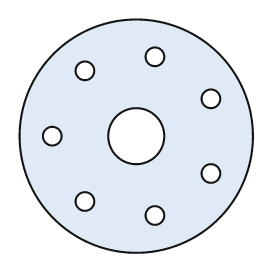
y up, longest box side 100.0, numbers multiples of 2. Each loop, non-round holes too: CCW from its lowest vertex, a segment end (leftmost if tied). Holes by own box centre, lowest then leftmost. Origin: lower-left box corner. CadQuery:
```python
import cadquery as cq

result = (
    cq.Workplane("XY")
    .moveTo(50.0, 50.0)
    .circle(50.0)
    .moveTo(58.0, 16.0)
    .circle(4.0)
    .moveTo(28.0, 22.0)
    .circle(4.0)
    .moveTo(82.0, 34.0)
    .circle(4.0)
    .moveTo(14.0, 50.0)
    .circle(4.0)
    .moveTo(50.0, 50.0)
    .circle(12.0)
    .moveTo(82.0, 66.0)
    .circle(4.0)
    .moveTo(28.0, 78.0)
    .circle(4.0)
    .moveTo(58.0, 84.0)
    .circle(4.0)
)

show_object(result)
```